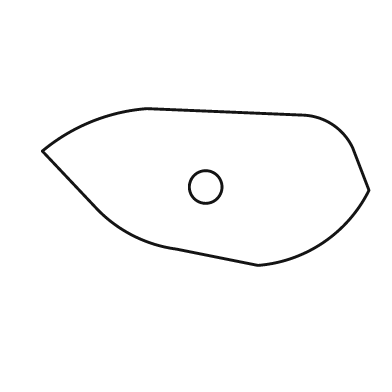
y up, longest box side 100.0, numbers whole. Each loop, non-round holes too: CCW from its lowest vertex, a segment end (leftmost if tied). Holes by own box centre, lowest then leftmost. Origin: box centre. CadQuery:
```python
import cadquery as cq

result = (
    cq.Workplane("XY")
    .moveTo(16.0, -24.0)
    .threePointArc((36.0, -17.0), (50.0, -1.0))
    .lineTo(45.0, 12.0)
    .threePointArc((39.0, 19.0), (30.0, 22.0))
    .lineTo(-18.0, 24.0)
    .threePointArc((-35.0, 20.0), (-50.0, 11.0))
    .lineTo(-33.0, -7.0)
    .threePointArc((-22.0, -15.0), (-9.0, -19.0))
    .close()
    .moveTo(0.0, 0.0)
    .circle(5.0)
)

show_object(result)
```